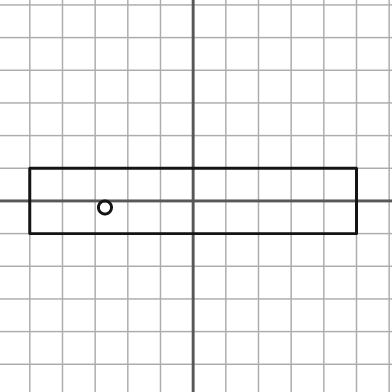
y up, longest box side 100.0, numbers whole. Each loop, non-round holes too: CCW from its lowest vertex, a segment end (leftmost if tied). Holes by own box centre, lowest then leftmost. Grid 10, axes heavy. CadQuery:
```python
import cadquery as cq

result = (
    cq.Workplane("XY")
    .moveTo(-50.0, -10.0)
    .lineTo(50.0, -10.0)
    .lineTo(50.0, 10.0)
    .lineTo(-50.0, 10.0)
    .close()
    .moveTo(-27.0, -2.0)
    .circle(2.0)
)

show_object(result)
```